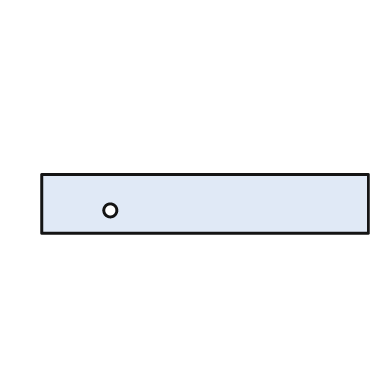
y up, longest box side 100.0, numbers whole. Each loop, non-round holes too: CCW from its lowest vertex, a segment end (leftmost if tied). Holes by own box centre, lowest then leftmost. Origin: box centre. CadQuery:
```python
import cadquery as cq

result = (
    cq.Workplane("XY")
    .moveTo(-50.0, -9.0)
    .lineTo(50.0, -9.0)
    .lineTo(50.0, 9.0)
    .lineTo(-50.0, 9.0)
    .close()
    .moveTo(-29.0, -2.0)
    .circle(2.0)
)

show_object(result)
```